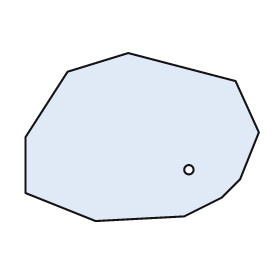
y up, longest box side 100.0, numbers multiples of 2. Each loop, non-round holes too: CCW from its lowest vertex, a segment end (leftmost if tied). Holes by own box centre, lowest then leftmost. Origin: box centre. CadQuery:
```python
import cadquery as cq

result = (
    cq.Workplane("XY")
    .moveTo(-20.0, -36.0)
    .lineTo(18.0, -34.0)
    .lineTo(34.0, -26.0)
    .lineTo(42.0, -18.0)
    .lineTo(50.0, 2.0)
    .lineTo(40.0, 24.0)
    .lineTo(-6.0, 36.0)
    .lineTo(-32.0, 28.0)
    .lineTo(-50.0, 0.0)
    .lineTo(-50.0, -24.0)
    .close()
    .moveTo(20.0, -14.0)
    .circle(2.0)
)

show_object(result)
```